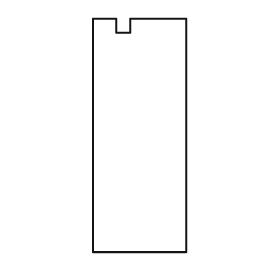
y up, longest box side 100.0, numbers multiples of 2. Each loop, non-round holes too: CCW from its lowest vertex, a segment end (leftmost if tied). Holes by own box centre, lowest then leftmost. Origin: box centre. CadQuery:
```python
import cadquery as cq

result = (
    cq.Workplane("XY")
    .moveTo(-20.0, -50.0)
    .lineTo(20.0, -50.0)
    .lineTo(20.0, 50.0)
    .lineTo(-4.0, 50.0)
    .lineTo(-4.0, 44.0)
    .lineTo(-10.0, 44.0)
    .lineTo(-10.0, 50.0)
    .lineTo(-20.0, 50.0)
    .close()
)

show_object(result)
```